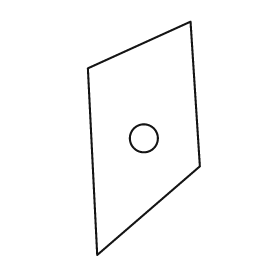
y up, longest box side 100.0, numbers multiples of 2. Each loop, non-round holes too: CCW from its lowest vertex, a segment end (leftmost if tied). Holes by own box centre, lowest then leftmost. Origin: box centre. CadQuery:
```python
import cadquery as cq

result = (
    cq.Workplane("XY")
    .moveTo(-20.0, -50.0)
    .lineTo(24.0, -12.0)
    .lineTo(20.0, 50.0)
    .lineTo(-24.0, 30.0)
    .close()
    .moveTo(0.0, 0.0)
    .circle(6.0)
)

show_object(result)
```